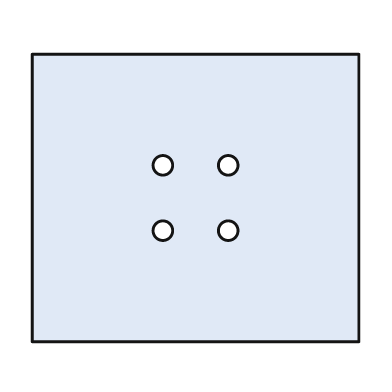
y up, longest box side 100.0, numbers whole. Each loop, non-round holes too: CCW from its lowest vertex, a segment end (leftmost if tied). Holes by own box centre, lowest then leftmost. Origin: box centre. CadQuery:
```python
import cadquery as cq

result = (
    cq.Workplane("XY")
    .moveTo(-50.0, -44.0)
    .lineTo(50.0, -44.0)
    .lineTo(50.0, 44.0)
    .lineTo(-50.0, 44.0)
    .close()
    .moveTo(-10.0, -10.0)
    .circle(3.0)
    .moveTo(10.0, -10.0)
    .circle(3.0)
    .moveTo(-10.0, 10.0)
    .circle(3.0)
    .moveTo(10.0, 10.0)
    .circle(3.0)
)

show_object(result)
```